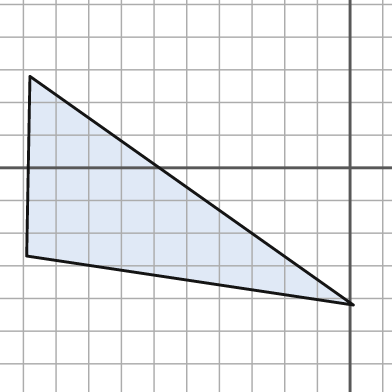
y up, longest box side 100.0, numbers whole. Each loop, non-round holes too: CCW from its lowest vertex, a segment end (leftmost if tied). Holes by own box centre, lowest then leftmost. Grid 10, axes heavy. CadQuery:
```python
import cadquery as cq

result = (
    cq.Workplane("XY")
    .moveTo(1.0, -42.0)
    .lineTo(-98.0, 28.0)
    .lineTo(-99.0, -27.0)
    .close()
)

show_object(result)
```